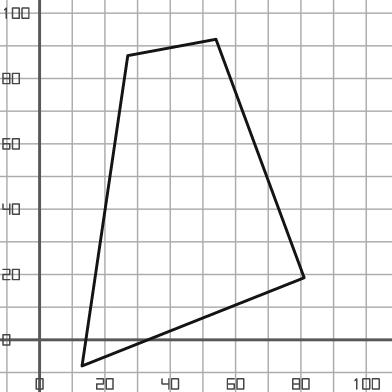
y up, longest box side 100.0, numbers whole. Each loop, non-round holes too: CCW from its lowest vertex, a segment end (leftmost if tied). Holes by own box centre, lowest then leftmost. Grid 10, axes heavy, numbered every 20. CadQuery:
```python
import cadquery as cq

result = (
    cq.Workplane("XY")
    .moveTo(13.0, -8.0)
    .lineTo(81.0, 19.0)
    .lineTo(54.0, 92.0)
    .lineTo(27.0, 87.0)
    .close()
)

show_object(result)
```